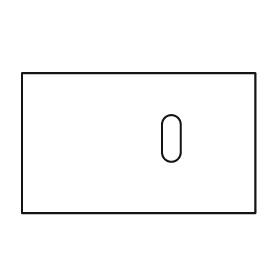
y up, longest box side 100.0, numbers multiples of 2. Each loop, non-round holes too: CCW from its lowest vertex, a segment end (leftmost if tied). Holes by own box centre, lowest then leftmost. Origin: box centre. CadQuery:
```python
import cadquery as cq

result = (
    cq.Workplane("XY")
    .moveTo(-50.0, -30.0)
    .lineTo(50.0, -30.0)
    .lineTo(50.0, 30.0)
    .lineTo(-50.0, 30.0)
    .close()
    .moveTo(10.0, -4.0)
    .threePointArc((14.0, -8.0), (18.0, -4.0))
    .lineTo(18.0, 8.0)
    .threePointArc((14.0, 12.0), (10.0, 8.0))
    .close()
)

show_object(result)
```